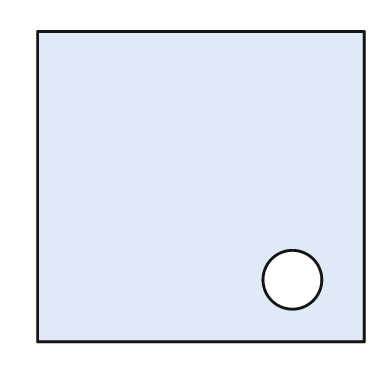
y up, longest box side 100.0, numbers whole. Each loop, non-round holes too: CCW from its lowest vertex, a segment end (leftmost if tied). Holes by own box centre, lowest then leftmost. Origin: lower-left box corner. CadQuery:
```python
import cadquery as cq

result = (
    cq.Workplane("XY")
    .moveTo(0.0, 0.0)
    .lineTo(100.0, 0.0)
    .lineTo(100.0, 95.0)
    .lineTo(0.0, 95.0)
    .close()
    .moveTo(78.0, 19.0)
    .circle(9.0)
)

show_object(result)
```